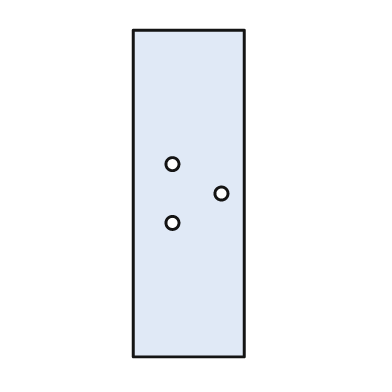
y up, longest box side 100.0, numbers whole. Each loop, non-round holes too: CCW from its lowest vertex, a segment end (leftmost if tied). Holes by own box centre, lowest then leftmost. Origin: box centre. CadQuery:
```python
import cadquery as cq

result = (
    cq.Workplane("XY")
    .moveTo(-17.0, -50.0)
    .lineTo(17.0, -50.0)
    .lineTo(17.0, 50.0)
    .lineTo(-17.0, 50.0)
    .close()
    .moveTo(-5.0, -9.0)
    .circle(2.0)
    .moveTo(10.0, 0.0)
    .circle(2.0)
    .moveTo(-5.0, 9.0)
    .circle(2.0)
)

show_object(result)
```